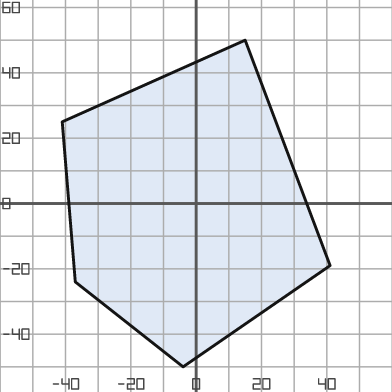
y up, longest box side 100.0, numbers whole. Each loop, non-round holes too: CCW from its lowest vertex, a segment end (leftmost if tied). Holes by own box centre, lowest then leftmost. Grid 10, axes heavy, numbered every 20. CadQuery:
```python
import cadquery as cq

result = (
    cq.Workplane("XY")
    .moveTo(-4.0, -50.0)
    .lineTo(41.0, -19.0)
    .lineTo(15.0, 50.0)
    .lineTo(-41.0, 25.0)
    .lineTo(-37.0, -24.0)
    .close()
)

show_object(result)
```